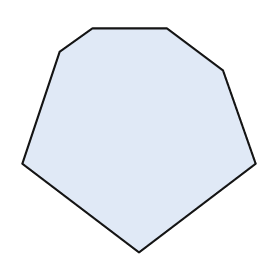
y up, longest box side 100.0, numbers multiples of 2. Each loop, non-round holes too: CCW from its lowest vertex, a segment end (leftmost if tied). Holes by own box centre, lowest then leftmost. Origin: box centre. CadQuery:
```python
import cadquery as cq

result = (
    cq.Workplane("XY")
    .moveTo(0.0, -48.0)
    .lineTo(50.0, -10.0)
    .lineTo(36.0, 30.0)
    .lineTo(12.0, 48.0)
    .lineTo(-20.0, 48.0)
    .lineTo(-34.0, 38.0)
    .lineTo(-50.0, -10.0)
    .close()
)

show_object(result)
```